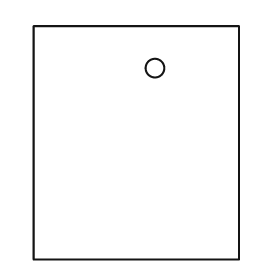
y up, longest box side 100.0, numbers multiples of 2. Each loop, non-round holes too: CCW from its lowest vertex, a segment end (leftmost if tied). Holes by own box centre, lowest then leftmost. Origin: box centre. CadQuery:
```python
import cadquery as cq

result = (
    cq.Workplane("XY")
    .moveTo(-44.0, -50.0)
    .lineTo(44.0, -50.0)
    .lineTo(44.0, 50.0)
    .lineTo(-44.0, 50.0)
    .close()
    .moveTo(8.0, 32.0)
    .circle(4.0)
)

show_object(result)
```